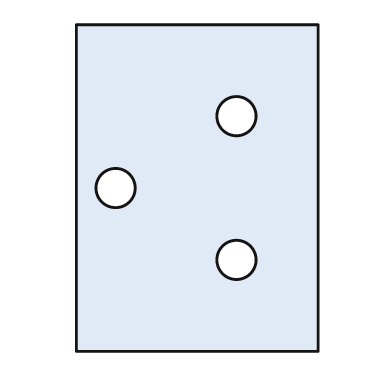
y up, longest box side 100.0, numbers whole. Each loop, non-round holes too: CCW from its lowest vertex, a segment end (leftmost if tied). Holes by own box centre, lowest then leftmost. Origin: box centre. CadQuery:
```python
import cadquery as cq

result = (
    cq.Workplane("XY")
    .moveTo(-37.0, -50.0)
    .lineTo(37.0, -50.0)
    .lineTo(37.0, 50.0)
    .lineTo(-37.0, 50.0)
    .close()
    .moveTo(12.0, -22.0)
    .circle(6.0)
    .moveTo(-25.0, 0.0)
    .circle(6.0)
    .moveTo(12.0, 22.0)
    .circle(6.0)
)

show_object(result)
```